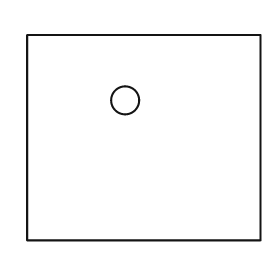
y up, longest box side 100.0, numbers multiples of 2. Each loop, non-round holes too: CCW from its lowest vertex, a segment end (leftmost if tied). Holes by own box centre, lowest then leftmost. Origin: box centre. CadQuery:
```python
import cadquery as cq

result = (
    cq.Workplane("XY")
    .moveTo(-50.0, -44.0)
    .lineTo(50.0, -44.0)
    .lineTo(50.0, 44.0)
    .lineTo(-50.0, 44.0)
    .close()
    .moveTo(-8.0, 16.0)
    .circle(6.0)
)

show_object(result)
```